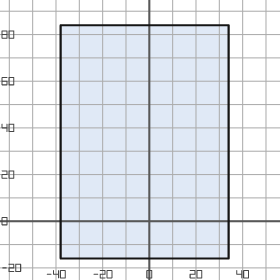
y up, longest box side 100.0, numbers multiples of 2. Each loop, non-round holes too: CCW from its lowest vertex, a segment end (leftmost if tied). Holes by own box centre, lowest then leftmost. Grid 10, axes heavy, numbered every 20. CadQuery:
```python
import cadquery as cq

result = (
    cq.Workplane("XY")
    .moveTo(-38.0, -16.0)
    .lineTo(34.0, -16.0)
    .lineTo(34.0, 84.0)
    .lineTo(-38.0, 84.0)
    .close()
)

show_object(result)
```